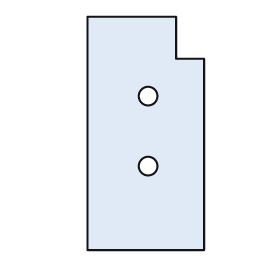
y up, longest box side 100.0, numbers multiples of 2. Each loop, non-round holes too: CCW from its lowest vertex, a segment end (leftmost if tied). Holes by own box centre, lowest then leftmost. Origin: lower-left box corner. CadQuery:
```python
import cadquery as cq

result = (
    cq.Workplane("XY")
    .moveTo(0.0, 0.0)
    .lineTo(50.0, 0.0)
    .lineTo(50.0, 82.0)
    .lineTo(38.0, 82.0)
    .lineTo(38.0, 100.0)
    .lineTo(0.0, 100.0)
    .close()
    .moveTo(26.0, 36.0)
    .circle(4.0)
    .moveTo(26.0, 66.0)
    .circle(4.0)
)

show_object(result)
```